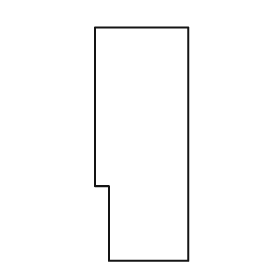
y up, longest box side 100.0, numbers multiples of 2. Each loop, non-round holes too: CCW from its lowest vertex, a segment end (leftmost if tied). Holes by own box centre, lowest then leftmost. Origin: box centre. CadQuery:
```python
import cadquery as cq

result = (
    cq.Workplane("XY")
    .moveTo(-14.0, -50.0)
    .lineTo(20.0, -50.0)
    .lineTo(20.0, 50.0)
    .lineTo(-20.0, 50.0)
    .lineTo(-20.0, -18.0)
    .lineTo(-14.0, -18.0)
    .close()
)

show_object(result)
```